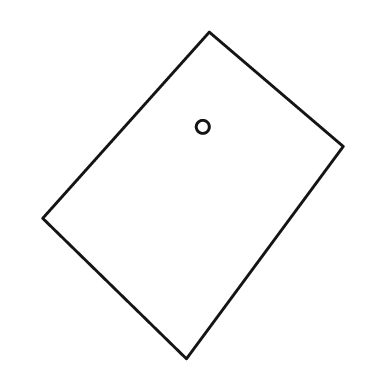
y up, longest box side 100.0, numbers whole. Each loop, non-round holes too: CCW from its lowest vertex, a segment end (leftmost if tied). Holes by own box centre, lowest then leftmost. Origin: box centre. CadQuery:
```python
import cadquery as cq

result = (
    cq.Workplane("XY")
    .moveTo(-2.0, -50.0)
    .lineTo(46.0, 15.0)
    .lineTo(5.0, 50.0)
    .lineTo(-46.0, -7.0)
    .close()
    .moveTo(3.0, 21.0)
    .circle(2.0)
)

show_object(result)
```